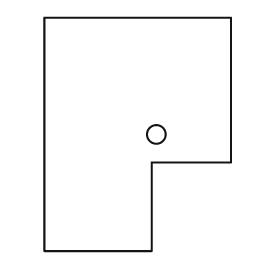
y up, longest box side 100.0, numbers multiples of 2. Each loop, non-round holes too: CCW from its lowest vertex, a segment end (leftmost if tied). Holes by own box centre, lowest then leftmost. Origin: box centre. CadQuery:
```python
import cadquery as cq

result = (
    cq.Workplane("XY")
    .moveTo(-40.0, -50.0)
    .lineTo(6.0, -50.0)
    .lineTo(6.0, -12.0)
    .lineTo(40.0, -12.0)
    .lineTo(40.0, 50.0)
    .lineTo(-40.0, 50.0)
    .close()
    .moveTo(8.0, 0.0)
    .circle(4.0)
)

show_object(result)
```